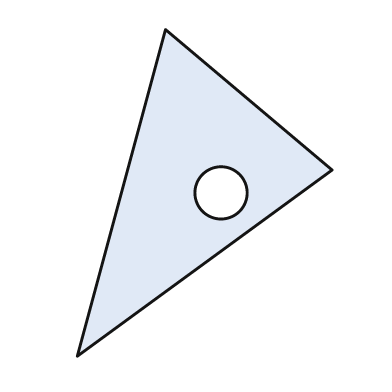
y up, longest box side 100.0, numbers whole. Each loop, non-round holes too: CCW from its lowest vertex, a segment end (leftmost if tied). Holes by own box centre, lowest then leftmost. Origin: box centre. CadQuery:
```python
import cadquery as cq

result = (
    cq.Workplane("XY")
    .moveTo(-39.0, -50.0)
    .lineTo(39.0, 7.0)
    .lineTo(-12.0, 50.0)
    .close()
    .moveTo(5.0, 0.0)
    .circle(8.0)
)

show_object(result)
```